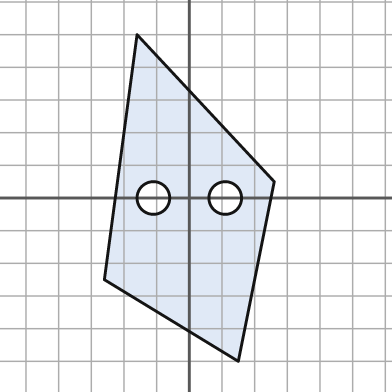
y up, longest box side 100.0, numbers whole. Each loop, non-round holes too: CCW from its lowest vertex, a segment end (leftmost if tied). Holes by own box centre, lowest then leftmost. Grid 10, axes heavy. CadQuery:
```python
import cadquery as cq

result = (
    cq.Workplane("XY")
    .moveTo(15.0, -50.0)
    .lineTo(26.0, 5.0)
    .lineTo(-16.0, 50.0)
    .lineTo(-26.0, -25.0)
    .close()
    .moveTo(-11.0, 0.0)
    .circle(5.0)
    .moveTo(11.0, 0.0)
    .circle(5.0)
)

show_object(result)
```